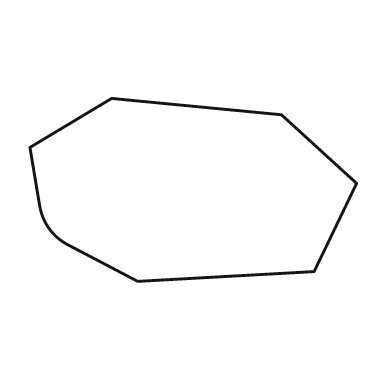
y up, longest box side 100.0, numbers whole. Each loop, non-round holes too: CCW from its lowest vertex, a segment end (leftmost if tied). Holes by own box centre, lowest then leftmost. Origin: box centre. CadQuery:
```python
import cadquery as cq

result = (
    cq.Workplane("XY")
    .moveTo(-17.0, -28.0)
    .lineTo(37.0, -25.0)
    .lineTo(50.0, 2.0)
    .lineTo(27.0, 23.0)
    .lineTo(-25.0, 28.0)
    .lineTo(-50.0, 13.0)
    .lineTo(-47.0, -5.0)
    .threePointArc((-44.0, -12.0), (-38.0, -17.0))
    .close()
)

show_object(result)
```